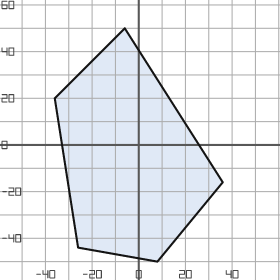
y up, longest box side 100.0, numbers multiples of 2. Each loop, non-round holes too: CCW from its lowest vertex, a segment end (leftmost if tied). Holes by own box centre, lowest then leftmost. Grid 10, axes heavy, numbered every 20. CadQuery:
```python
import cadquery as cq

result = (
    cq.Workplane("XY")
    .moveTo(8.0, -50.0)
    .lineTo(36.0, -16.0)
    .lineTo(-6.0, 50.0)
    .lineTo(-36.0, 20.0)
    .lineTo(-26.0, -44.0)
    .close()
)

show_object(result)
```